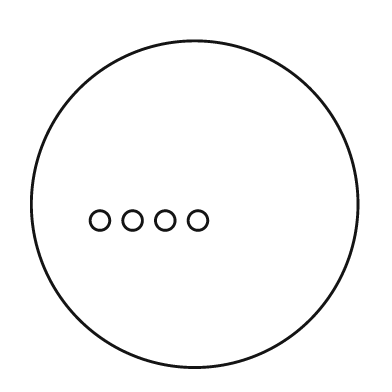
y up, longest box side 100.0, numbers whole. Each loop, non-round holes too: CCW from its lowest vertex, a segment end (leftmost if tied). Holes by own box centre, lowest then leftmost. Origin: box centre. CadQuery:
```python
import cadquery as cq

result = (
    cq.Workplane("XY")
    .moveTo(0.0, 0.0)
    .circle(50.0)
    .moveTo(-29.0, -5.0)
    .circle(3.0)
    .moveTo(-19.0, -5.0)
    .circle(3.0)
    .moveTo(-9.0, -5.0)
    .circle(3.0)
    .moveTo(1.0, -5.0)
    .circle(3.0)
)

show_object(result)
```